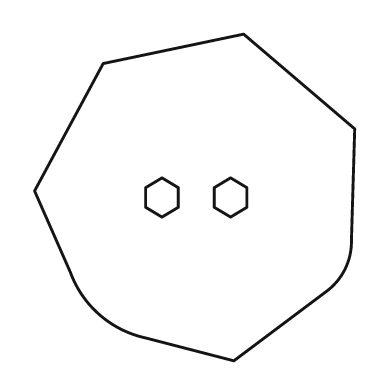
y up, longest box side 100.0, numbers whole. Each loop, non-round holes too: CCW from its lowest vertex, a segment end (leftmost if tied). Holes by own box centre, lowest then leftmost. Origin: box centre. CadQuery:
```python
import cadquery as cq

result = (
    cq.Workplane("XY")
    .moveTo(12.0, -50.0)
    .lineTo(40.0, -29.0)
    .threePointArc((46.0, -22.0), (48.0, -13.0))
    .lineTo(49.0, 21.0)
    .lineTo(15.0, 50.0)
    .lineTo(-28.0, 41.0)
    .lineTo(-49.0, 2.0)
    .lineTo(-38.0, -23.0)
    .threePointArc((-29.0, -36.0), (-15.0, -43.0))
    .close()
    .moveTo(-10.0, -6.0)
    .lineTo(-5.0, -3.0)
    .lineTo(-5.0, 3.0)
    .lineTo(-10.0, 6.0)
    .lineTo(-15.0, 3.0)
    .lineTo(-15.0, -3.0)
    .close()
    .moveTo(11.0, -6.0)
    .lineTo(16.0, -3.0)
    .lineTo(16.0, 3.0)
    .lineTo(11.0, 6.0)
    .lineTo(6.0, 3.0)
    .lineTo(6.0, -3.0)
    .close()
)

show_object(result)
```